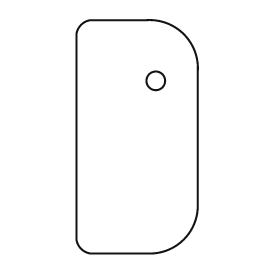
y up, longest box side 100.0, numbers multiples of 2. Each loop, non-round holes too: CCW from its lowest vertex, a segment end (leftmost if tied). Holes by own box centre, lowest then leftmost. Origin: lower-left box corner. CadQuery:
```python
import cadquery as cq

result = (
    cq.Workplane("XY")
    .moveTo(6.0, 0.0)
    .lineTo(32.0, 0.0)
    .threePointArc((46.0, 6.0), (52.0, 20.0))
    .lineTo(52.0, 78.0)
    .threePointArc((46.0, 94.0), (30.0, 100.0))
    .lineTo(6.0, 100.0)
    .threePointArc((2.0, 98.0), (0.0, 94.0))
    .lineTo(0.0, 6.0)
    .threePointArc((2.0, 2.0), (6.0, 0.0))
    .close()
    .moveTo(34.0, 74.0)
    .circle(4.0)
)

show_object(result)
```